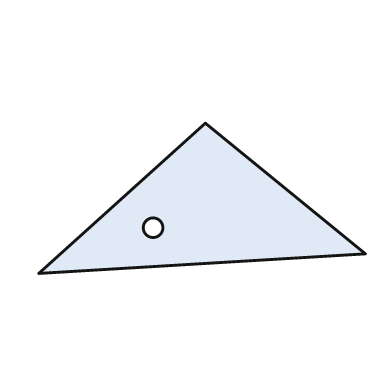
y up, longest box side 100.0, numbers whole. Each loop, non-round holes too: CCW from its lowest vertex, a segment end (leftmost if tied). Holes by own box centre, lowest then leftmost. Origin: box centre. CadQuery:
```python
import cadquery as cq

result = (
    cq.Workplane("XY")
    .moveTo(-50.0, -23.0)
    .lineTo(50.0, -17.0)
    .lineTo(1.0, 23.0)
    .close()
    .moveTo(-15.0, -9.0)
    .circle(3.0)
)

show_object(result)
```